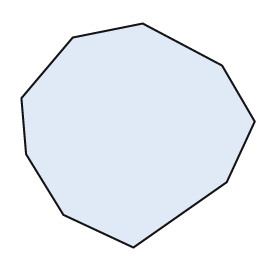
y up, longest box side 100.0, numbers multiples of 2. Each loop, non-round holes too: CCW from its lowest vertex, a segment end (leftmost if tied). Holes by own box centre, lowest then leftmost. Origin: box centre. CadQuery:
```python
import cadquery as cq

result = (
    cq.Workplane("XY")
    .moveTo(-2.0, -48.0)
    .lineTo(38.0, -20.0)
    .lineTo(50.0, 6.0)
    .lineTo(36.0, 30.0)
    .lineTo(2.0, 48.0)
    .lineTo(-28.0, 42.0)
    .lineTo(-50.0, 16.0)
    .lineTo(-48.0, -8.0)
    .lineTo(-32.0, -34.0)
    .close()
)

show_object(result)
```